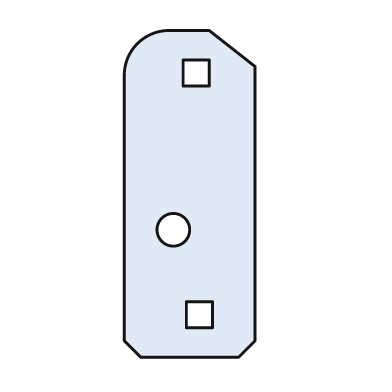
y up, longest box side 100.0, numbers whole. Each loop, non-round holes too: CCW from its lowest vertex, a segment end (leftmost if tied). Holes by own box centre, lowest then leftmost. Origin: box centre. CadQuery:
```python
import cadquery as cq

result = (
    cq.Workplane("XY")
    .moveTo(-15.0, -50.0)
    .lineTo(15.0, -50.0)
    .lineTo(20.0, -45.0)
    .lineTo(20.0, 39.0)
    .lineTo(6.0, 50.0)
    .lineTo(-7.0, 50.0)
    .threePointArc((-16.0, 46.0), (-20.0, 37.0))
    .lineTo(-20.0, -45.0)
    .close()
    .moveTo(-1.0, -41.0)
    .lineTo(7.0, -41.0)
    .lineTo(7.0, -33.0)
    .lineTo(-1.0, -33.0)
    .close()
    .moveTo(-5.0, -11.0)
    .circle(5.0)
    .moveTo(-2.0, 33.0)
    .lineTo(6.0, 33.0)
    .lineTo(6.0, 41.0)
    .lineTo(-2.0, 41.0)
    .close()
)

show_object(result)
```